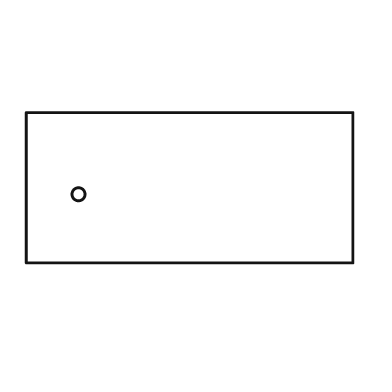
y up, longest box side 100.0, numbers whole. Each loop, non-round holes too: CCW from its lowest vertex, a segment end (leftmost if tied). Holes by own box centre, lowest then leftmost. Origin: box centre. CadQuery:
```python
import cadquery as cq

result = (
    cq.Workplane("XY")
    .moveTo(-50.0, -23.0)
    .lineTo(50.0, -23.0)
    .lineTo(50.0, 23.0)
    .lineTo(-50.0, 23.0)
    .close()
    .moveTo(-34.0, -2.0)
    .circle(2.0)
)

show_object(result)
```